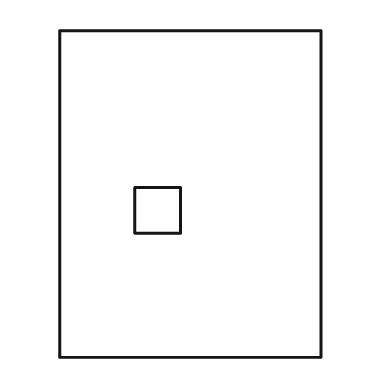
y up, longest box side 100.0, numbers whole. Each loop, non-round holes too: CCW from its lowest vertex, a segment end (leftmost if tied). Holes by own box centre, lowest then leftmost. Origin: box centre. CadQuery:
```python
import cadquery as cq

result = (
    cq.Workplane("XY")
    .moveTo(-40.0, -50.0)
    .lineTo(40.0, -50.0)
    .lineTo(40.0, 50.0)
    .lineTo(-40.0, 50.0)
    .close()
    .moveTo(-17.0, -12.0)
    .lineTo(-3.0, -12.0)
    .lineTo(-3.0, 2.0)
    .lineTo(-17.0, 2.0)
    .close()
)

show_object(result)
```